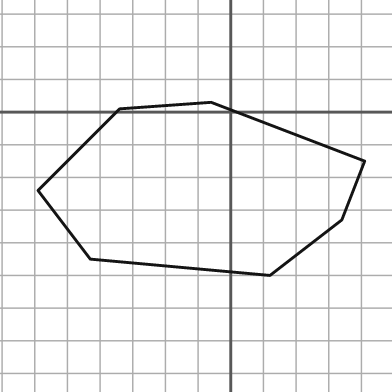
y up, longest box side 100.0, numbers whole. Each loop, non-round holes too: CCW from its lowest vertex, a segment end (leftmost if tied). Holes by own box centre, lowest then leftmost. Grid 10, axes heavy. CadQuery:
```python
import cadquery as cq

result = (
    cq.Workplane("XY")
    .moveTo(12.0, -50.0)
    .lineTo(34.0, -33.0)
    .lineTo(41.0, -15.0)
    .lineTo(-6.0, 3.0)
    .lineTo(-34.0, 1.0)
    .lineTo(-59.0, -24.0)
    .lineTo(-43.0, -45.0)
    .close()
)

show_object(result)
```